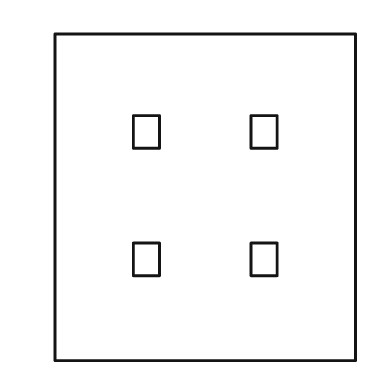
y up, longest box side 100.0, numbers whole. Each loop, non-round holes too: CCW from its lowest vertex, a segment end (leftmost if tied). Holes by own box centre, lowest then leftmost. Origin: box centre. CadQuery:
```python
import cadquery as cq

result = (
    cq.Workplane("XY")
    .moveTo(-46.0, -50.0)
    .lineTo(46.0, -50.0)
    .lineTo(46.0, 50.0)
    .lineTo(-46.0, 50.0)
    .close()
    .moveTo(-22.0, -24.0)
    .lineTo(-14.0, -24.0)
    .lineTo(-14.0, -14.0)
    .lineTo(-22.0, -14.0)
    .close()
    .moveTo(14.0, -24.0)
    .lineTo(22.0, -24.0)
    .lineTo(22.0, -14.0)
    .lineTo(14.0, -14.0)
    .close()
    .moveTo(-22.0, 15.0)
    .lineTo(-14.0, 15.0)
    .lineTo(-14.0, 25.0)
    .lineTo(-22.0, 25.0)
    .close()
    .moveTo(14.0, 15.0)
    .lineTo(22.0, 15.0)
    .lineTo(22.0, 25.0)
    .lineTo(14.0, 25.0)
    .close()
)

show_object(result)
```